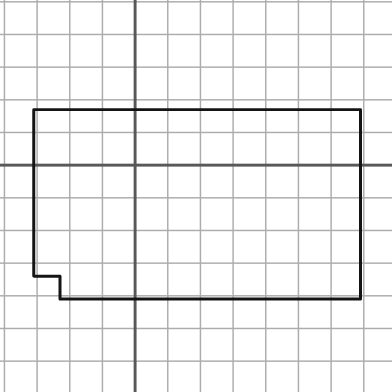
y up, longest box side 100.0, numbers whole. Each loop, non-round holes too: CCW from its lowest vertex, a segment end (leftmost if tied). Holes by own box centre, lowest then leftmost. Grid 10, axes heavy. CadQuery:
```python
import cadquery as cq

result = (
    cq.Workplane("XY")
    .moveTo(-23.0, -41.0)
    .lineTo(69.0, -41.0)
    .lineTo(69.0, 17.0)
    .lineTo(-31.0, 17.0)
    .lineTo(-31.0, -34.0)
    .lineTo(-23.0, -34.0)
    .close()
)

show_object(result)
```